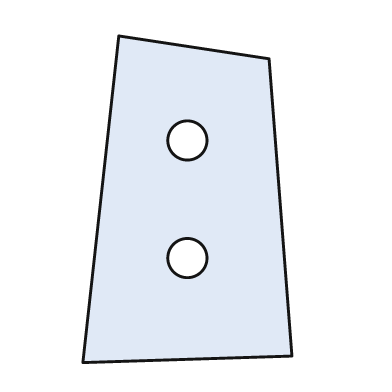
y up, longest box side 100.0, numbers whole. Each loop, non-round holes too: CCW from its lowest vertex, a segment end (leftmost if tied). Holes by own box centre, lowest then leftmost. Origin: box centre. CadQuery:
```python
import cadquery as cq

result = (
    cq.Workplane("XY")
    .moveTo(-32.0, -50.0)
    .lineTo(32.0, -48.0)
    .lineTo(25.0, 43.0)
    .lineTo(-21.0, 50.0)
    .close()
    .moveTo(0.0, -18.0)
    .circle(6.0)
    .moveTo(0.0, 18.0)
    .circle(6.0)
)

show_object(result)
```